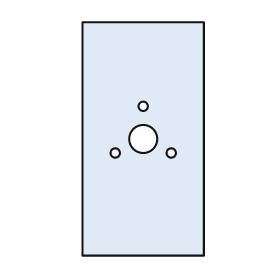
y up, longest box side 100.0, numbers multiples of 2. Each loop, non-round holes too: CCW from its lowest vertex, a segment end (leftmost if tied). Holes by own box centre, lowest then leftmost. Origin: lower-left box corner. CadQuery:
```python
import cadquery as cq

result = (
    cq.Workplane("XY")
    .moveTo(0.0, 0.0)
    .lineTo(52.0, 0.0)
    .lineTo(52.0, 100.0)
    .lineTo(0.0, 100.0)
    .close()
    .moveTo(14.0, 44.0)
    .circle(2.0)
    .moveTo(38.0, 44.0)
    .circle(2.0)
    .moveTo(26.0, 50.0)
    .circle(6.0)
    .moveTo(26.0, 64.0)
    .circle(2.0)
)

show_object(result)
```